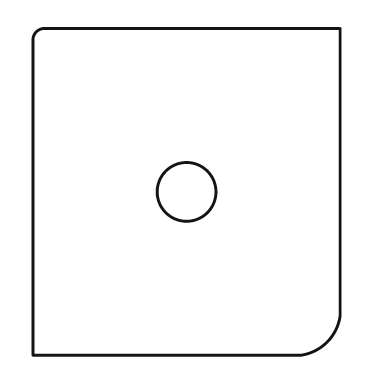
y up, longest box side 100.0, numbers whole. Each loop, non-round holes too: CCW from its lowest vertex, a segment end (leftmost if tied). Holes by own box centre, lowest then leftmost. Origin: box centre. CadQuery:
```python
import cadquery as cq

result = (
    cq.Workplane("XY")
    .moveTo(-47.0, -50.0)
    .lineTo(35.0, -50.0)
    .threePointArc((43.0, -46.0), (47.0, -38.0))
    .lineTo(47.0, 50.0)
    .lineTo(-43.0, 50.0)
    .threePointArc((-46.0, 49.0), (-47.0, 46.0))
    .close()
    .moveTo(0.0, 0.0)
    .circle(9.0)
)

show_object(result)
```